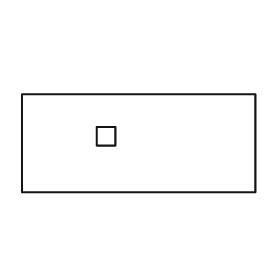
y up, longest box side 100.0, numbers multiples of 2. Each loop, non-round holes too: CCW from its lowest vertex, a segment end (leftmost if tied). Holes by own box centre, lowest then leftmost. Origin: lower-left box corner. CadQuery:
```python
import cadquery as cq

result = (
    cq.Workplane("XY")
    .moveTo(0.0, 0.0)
    .lineTo(100.0, 0.0)
    .lineTo(100.0, 42.0)
    .lineTo(0.0, 42.0)
    .close()
    .moveTo(32.0, 20.0)
    .lineTo(40.0, 20.0)
    .lineTo(40.0, 28.0)
    .lineTo(32.0, 28.0)
    .close()
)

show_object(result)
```